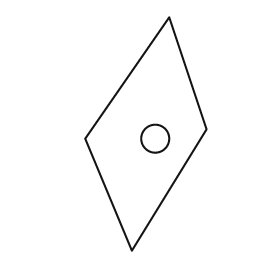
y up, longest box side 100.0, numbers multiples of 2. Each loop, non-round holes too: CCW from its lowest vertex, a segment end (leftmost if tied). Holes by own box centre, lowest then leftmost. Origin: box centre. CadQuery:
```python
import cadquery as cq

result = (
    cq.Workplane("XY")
    .moveTo(-6.0, -50.0)
    .lineTo(26.0, 2.0)
    .lineTo(10.0, 50.0)
    .lineTo(-26.0, -2.0)
    .close()
    .moveTo(4.0, -2.0)
    .circle(6.0)
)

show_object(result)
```